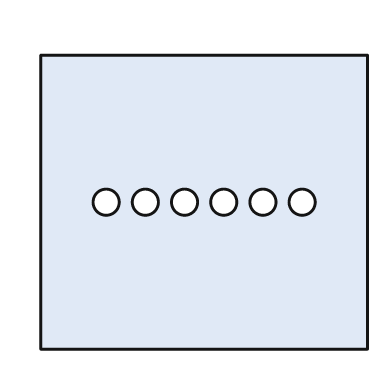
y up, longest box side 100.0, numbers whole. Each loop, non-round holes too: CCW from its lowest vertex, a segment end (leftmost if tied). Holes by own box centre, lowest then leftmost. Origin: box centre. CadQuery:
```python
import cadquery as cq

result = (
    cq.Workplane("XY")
    .moveTo(-50.0, -45.0)
    .lineTo(50.0, -45.0)
    .lineTo(50.0, 45.0)
    .lineTo(-50.0, 45.0)
    .close()
    .moveTo(-30.0, 0.0)
    .circle(4.0)
    .moveTo(-18.0, 0.0)
    .circle(4.0)
    .moveTo(-6.0, 0.0)
    .circle(4.0)
    .moveTo(6.0, 0.0)
    .circle(4.0)
    .moveTo(18.0, 0.0)
    .circle(4.0)
    .moveTo(30.0, 0.0)
    .circle(4.0)
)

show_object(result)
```